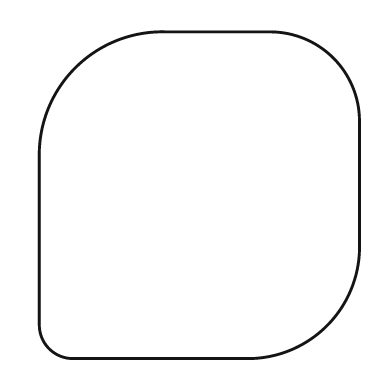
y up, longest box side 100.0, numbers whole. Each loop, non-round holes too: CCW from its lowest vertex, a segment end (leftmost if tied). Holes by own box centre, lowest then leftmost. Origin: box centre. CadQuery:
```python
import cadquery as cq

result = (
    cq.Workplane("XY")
    .moveTo(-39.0, -50.0)
    .lineTo(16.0, -50.0)
    .threePointArc((39.0, -40.0), (49.0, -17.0))
    .lineTo(49.0, 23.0)
    .threePointArc((41.0, 42.0), (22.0, 50.0))
    .lineTo(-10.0, 50.0)
    .threePointArc((-38.0, 39.0), (-49.0, 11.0))
    .lineTo(-49.0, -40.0)
    .threePointArc((-46.0, -47.0), (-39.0, -50.0))
    .close()
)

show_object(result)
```